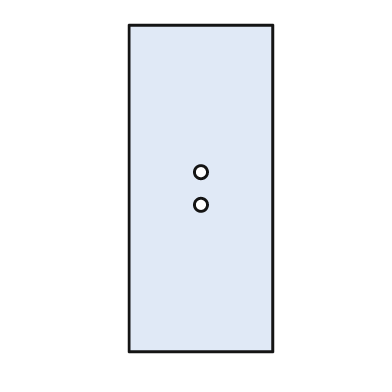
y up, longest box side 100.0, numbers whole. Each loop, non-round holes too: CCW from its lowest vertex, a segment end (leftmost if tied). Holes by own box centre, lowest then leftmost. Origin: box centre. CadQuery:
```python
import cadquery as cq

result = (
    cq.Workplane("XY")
    .moveTo(-22.0, -50.0)
    .lineTo(22.0, -50.0)
    .lineTo(22.0, 50.0)
    .lineTo(-22.0, 50.0)
    .close()
    .moveTo(0.0, -5.0)
    .circle(2.0)
    .moveTo(0.0, 5.0)
    .circle(2.0)
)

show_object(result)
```